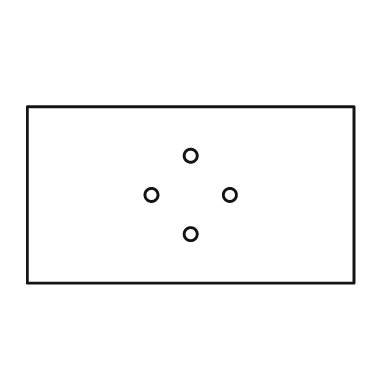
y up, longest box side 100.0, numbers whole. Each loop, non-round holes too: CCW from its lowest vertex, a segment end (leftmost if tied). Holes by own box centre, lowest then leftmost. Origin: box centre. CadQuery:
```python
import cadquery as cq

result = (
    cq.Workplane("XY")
    .moveTo(-50.0, -27.0)
    .lineTo(50.0, -27.0)
    .lineTo(50.0, 27.0)
    .lineTo(-50.0, 27.0)
    .close()
    .moveTo(0.0, -12.0)
    .circle(2.0)
    .moveTo(-12.0, 0.0)
    .circle(2.0)
    .moveTo(12.0, 0.0)
    .circle(2.0)
    .moveTo(0.0, 12.0)
    .circle(2.0)
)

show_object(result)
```